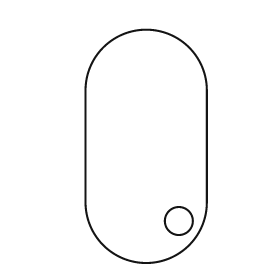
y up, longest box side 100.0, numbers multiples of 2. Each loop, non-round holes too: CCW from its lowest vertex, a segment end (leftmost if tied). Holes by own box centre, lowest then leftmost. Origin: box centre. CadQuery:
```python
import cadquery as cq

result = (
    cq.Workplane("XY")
    .moveTo(-26.0, -24.0)
    .threePointArc((0.0, -50.0), (26.0, -24.0))
    .lineTo(26.0, 24.0)
    .threePointArc((0.0, 50.0), (-26.0, 24.0))
    .close()
    .moveTo(14.0, -32.0)
    .circle(6.0)
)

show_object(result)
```